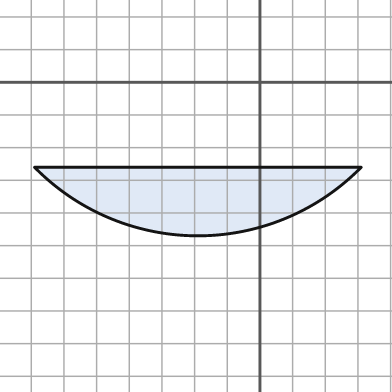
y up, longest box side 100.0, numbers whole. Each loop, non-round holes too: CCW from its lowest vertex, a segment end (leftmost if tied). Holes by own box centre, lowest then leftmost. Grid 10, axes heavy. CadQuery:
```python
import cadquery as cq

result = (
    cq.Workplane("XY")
    .moveTo(-69.0, -26.0)
    .threePointArc((-19.0, -47.0), (31.0, -26.0))
    .close()
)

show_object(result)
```